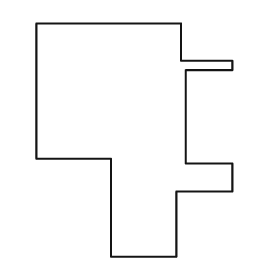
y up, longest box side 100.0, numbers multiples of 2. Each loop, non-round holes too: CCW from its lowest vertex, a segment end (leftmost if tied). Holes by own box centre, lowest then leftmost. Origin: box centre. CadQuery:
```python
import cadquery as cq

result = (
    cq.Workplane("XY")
    .moveTo(-10.0, -50.0)
    .lineTo(18.0, -50.0)
    .lineTo(18.0, -22.0)
    .lineTo(42.0, -22.0)
    .lineTo(42.0, -10.0)
    .lineTo(22.0, -10.0)
    .lineTo(22.0, 30.0)
    .lineTo(42.0, 30.0)
    .lineTo(42.0, 34.0)
    .lineTo(20.0, 34.0)
    .lineTo(20.0, 50.0)
    .lineTo(-42.0, 50.0)
    .lineTo(-42.0, -8.0)
    .lineTo(-10.0, -8.0)
    .close()
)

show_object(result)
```